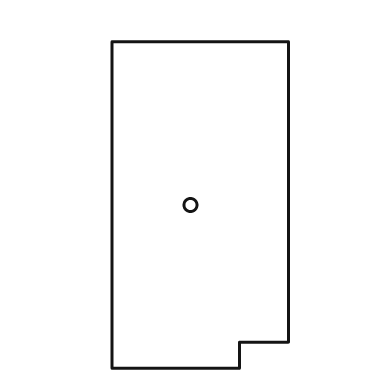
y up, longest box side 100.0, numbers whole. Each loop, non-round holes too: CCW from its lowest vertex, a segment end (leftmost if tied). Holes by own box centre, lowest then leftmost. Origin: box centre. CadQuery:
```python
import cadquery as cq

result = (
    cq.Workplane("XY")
    .moveTo(-27.0, -50.0)
    .lineTo(12.0, -50.0)
    .lineTo(12.0, -42.0)
    .lineTo(27.0, -42.0)
    .lineTo(27.0, 50.0)
    .lineTo(-27.0, 50.0)
    .close()
    .moveTo(-3.0, 0.0)
    .circle(2.0)
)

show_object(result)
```